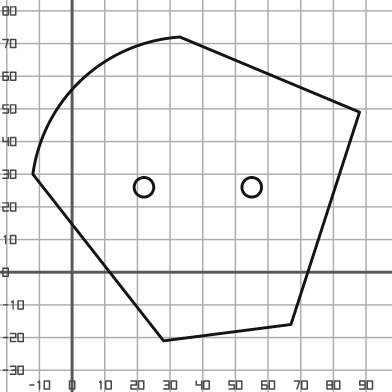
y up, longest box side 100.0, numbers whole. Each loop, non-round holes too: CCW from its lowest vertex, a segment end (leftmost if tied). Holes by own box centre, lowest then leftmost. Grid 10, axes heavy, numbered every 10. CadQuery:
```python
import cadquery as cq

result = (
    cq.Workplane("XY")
    .moveTo(28.0, -21.0)
    .lineTo(67.0, -16.0)
    .lineTo(88.0, 49.0)
    .lineTo(33.0, 72.0)
    .threePointArc((3.0, 59.0), (-12.0, 30.0))
    .close()
    .moveTo(22.0, 26.0)
    .circle(3.0)
    .moveTo(55.0, 26.0)
    .circle(3.0)
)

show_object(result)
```